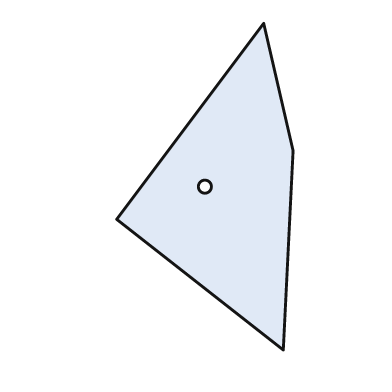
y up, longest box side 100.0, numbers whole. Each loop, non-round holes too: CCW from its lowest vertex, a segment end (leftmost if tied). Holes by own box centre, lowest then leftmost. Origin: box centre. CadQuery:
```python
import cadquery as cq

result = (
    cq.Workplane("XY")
    .moveTo(24.0, -50.0)
    .lineTo(27.0, 11.0)
    .lineTo(18.0, 50.0)
    .lineTo(-27.0, -10.0)
    .close()
    .moveTo(0.0, 0.0)
    .circle(2.0)
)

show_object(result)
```